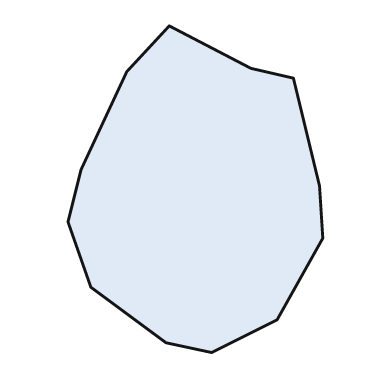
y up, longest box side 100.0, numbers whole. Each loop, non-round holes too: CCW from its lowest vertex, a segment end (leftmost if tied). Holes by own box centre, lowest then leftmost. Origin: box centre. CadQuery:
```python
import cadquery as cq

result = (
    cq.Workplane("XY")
    .moveTo(5.0, -50.0)
    .lineTo(25.0, -40.0)
    .lineTo(39.0, -15.0)
    .lineTo(38.0, 1.0)
    .lineTo(30.0, 34.0)
    .lineTo(17.0, 37.0)
    .lineTo(-8.0, 50.0)
    .lineTo(-21.0, 36.0)
    .lineTo(-35.0, 6.0)
    .lineTo(-39.0, -10.0)
    .lineTo(-32.0, -30.0)
    .lineTo(-9.0, -47.0)
    .close()
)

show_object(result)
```